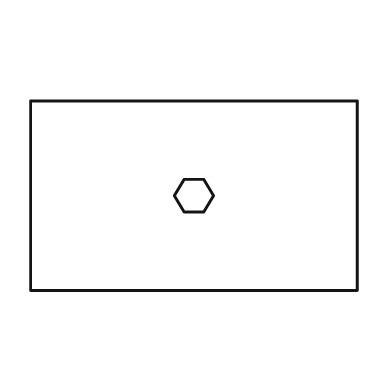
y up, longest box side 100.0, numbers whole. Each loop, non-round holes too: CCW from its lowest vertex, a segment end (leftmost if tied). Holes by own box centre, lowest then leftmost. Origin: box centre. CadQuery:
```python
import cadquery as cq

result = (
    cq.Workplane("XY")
    .moveTo(-50.0, -29.0)
    .lineTo(50.0, -29.0)
    .lineTo(50.0, 29.0)
    .lineTo(-50.0, 29.0)
    .close()
    .moveTo(-3.0, -5.0)
    .lineTo(3.0, -5.0)
    .lineTo(6.0, 0.0)
    .lineTo(3.0, 5.0)
    .lineTo(-3.0, 5.0)
    .lineTo(-6.0, 0.0)
    .close()
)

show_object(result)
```